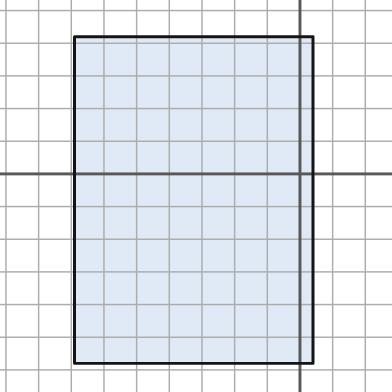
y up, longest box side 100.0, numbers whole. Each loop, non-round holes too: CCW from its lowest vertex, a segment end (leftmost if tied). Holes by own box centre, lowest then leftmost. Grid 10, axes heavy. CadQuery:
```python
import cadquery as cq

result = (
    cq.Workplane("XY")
    .moveTo(-69.0, -58.0)
    .lineTo(4.0, -58.0)
    .lineTo(4.0, 42.0)
    .lineTo(-69.0, 42.0)
    .close()
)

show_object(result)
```